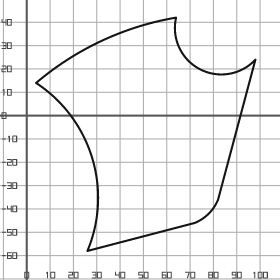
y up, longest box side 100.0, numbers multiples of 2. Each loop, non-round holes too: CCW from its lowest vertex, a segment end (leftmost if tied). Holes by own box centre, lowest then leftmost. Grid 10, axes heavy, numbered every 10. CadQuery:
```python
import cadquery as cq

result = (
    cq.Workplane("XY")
    .moveTo(26.0, -58.0)
    .lineTo(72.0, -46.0)
    .threePointArc((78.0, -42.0), (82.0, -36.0))
    .lineTo(98.0, 24.0)
    .threePointArc((74.0, 20.0), (64.0, 42.0))
    .threePointArc((32.0, 32.0), (4.0, 14.0))
    .threePointArc((28.0, -18.0), (26.0, -58.0))
    .close()
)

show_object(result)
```